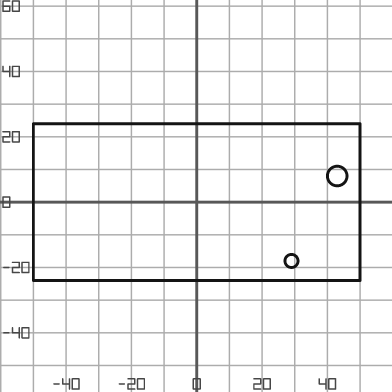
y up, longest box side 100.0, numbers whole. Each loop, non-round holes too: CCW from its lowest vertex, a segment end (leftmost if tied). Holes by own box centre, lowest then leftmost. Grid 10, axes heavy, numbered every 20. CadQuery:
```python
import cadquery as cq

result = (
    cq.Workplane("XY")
    .moveTo(-50.0, -24.0)
    .lineTo(50.0, -24.0)
    .lineTo(50.0, 24.0)
    .lineTo(-50.0, 24.0)
    .close()
    .moveTo(29.0, -18.0)
    .circle(2.0)
    .moveTo(43.0, 8.0)
    .circle(3.0)
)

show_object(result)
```